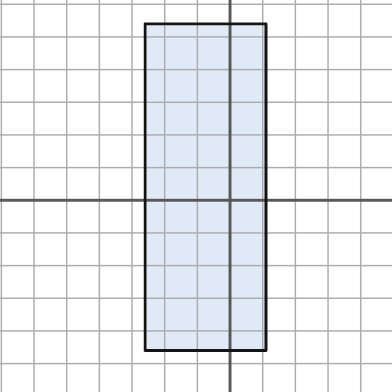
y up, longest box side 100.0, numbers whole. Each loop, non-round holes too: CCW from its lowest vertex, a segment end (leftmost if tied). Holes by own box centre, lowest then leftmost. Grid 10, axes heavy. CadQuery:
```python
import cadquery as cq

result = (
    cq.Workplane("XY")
    .moveTo(-26.0, -46.0)
    .lineTo(11.0, -46.0)
    .lineTo(11.0, 54.0)
    .lineTo(-26.0, 54.0)
    .close()
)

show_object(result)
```